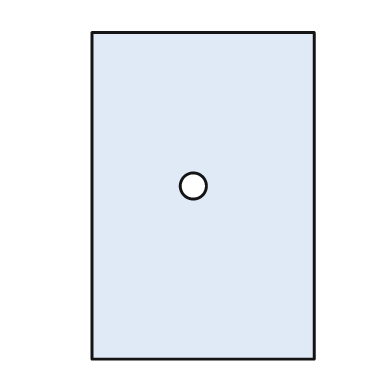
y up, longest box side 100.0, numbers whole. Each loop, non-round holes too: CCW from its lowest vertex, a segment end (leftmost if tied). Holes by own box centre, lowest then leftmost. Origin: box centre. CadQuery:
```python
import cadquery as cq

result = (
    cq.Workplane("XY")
    .moveTo(-34.0, -50.0)
    .lineTo(34.0, -50.0)
    .lineTo(34.0, 50.0)
    .lineTo(-34.0, 50.0)
    .close()
    .moveTo(-3.0, 3.0)
    .circle(4.0)
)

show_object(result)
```